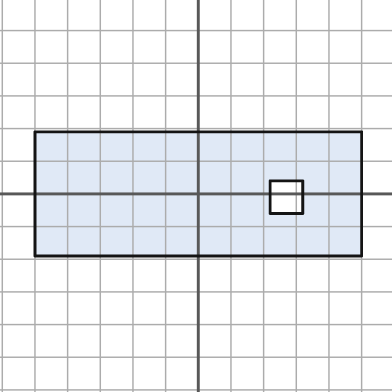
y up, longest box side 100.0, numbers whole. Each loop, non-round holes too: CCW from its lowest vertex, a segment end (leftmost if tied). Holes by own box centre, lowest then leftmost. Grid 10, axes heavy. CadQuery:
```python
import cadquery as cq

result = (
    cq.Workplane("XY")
    .moveTo(-50.0, -19.0)
    .lineTo(50.0, -19.0)
    .lineTo(50.0, 19.0)
    .lineTo(-50.0, 19.0)
    .close()
    .moveTo(22.0, -6.0)
    .lineTo(32.0, -6.0)
    .lineTo(32.0, 4.0)
    .lineTo(22.0, 4.0)
    .close()
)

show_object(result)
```